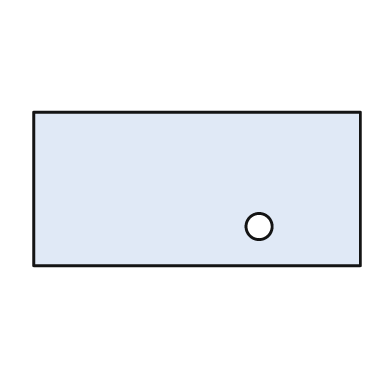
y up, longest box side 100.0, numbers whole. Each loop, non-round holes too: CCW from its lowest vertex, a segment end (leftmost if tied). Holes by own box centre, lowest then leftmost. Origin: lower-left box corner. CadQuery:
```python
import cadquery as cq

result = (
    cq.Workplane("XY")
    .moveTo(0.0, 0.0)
    .lineTo(100.0, 0.0)
    .lineTo(100.0, 47.0)
    .lineTo(0.0, 47.0)
    .close()
    .moveTo(69.0, 12.0)
    .circle(4.0)
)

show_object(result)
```